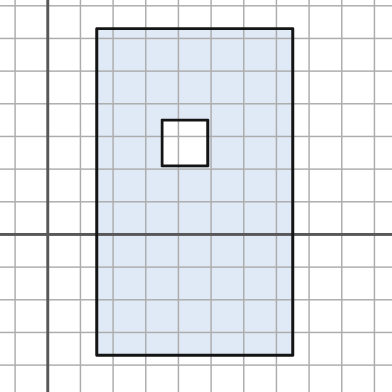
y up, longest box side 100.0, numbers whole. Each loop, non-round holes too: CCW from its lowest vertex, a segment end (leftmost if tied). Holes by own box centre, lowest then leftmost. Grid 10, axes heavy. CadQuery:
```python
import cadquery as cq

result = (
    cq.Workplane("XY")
    .moveTo(15.0, -37.0)
    .lineTo(75.0, -37.0)
    .lineTo(75.0, 63.0)
    .lineTo(15.0, 63.0)
    .close()
    .moveTo(35.0, 21.0)
    .lineTo(49.0, 21.0)
    .lineTo(49.0, 35.0)
    .lineTo(35.0, 35.0)
    .close()
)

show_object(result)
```